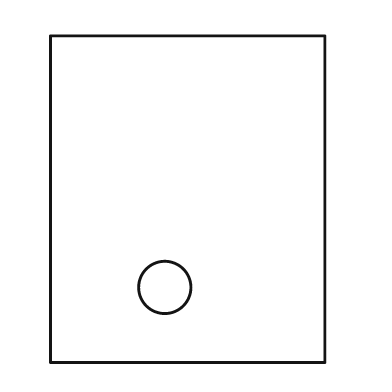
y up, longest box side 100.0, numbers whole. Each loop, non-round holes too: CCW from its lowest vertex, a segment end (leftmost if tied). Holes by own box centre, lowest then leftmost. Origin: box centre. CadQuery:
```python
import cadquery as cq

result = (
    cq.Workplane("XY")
    .moveTo(-42.0, -50.0)
    .lineTo(42.0, -50.0)
    .lineTo(42.0, 50.0)
    .lineTo(-42.0, 50.0)
    .close()
    .moveTo(-7.0, -27.0)
    .circle(8.0)
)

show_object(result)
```